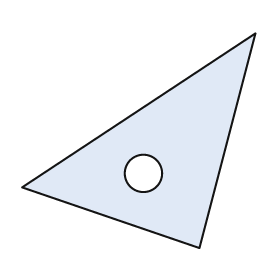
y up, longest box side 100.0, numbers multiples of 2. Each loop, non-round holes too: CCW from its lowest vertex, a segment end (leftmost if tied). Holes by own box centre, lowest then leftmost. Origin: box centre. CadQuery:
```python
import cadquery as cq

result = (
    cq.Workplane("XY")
    .moveTo(26.0, -46.0)
    .lineTo(50.0, 46.0)
    .lineTo(-50.0, -20.0)
    .close()
    .moveTo(2.0, -14.0)
    .circle(8.0)
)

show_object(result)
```